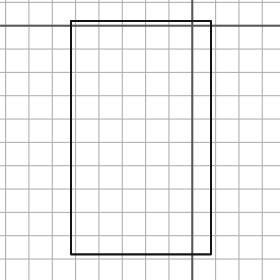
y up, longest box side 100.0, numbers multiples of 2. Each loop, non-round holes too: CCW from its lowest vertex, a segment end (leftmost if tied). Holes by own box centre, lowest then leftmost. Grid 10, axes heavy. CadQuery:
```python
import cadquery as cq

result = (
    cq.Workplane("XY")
    .moveTo(-52.0, -98.0)
    .lineTo(8.0, -98.0)
    .lineTo(8.0, 2.0)
    .lineTo(-52.0, 2.0)
    .close()
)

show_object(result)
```